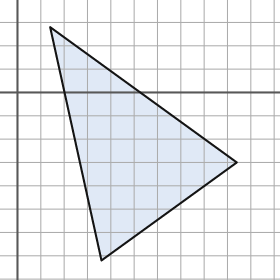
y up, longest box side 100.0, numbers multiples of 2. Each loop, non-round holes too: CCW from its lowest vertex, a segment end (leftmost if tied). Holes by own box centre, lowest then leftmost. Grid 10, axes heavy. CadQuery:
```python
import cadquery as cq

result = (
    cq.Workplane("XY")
    .moveTo(36.0, -72.0)
    .lineTo(94.0, -30.0)
    .lineTo(14.0, 28.0)
    .close()
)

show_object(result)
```